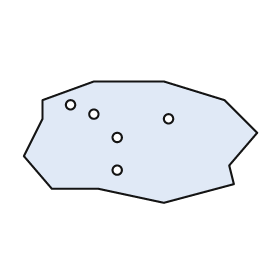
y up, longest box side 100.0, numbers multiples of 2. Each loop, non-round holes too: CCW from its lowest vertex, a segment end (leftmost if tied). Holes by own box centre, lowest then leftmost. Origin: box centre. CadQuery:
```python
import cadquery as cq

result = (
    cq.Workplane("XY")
    .moveTo(10.0, -26.0)
    .lineTo(40.0, -18.0)
    .lineTo(38.0, -10.0)
    .lineTo(50.0, 4.0)
    .lineTo(36.0, 18.0)
    .lineTo(10.0, 26.0)
    .lineTo(-20.0, 26.0)
    .lineTo(-42.0, 18.0)
    .lineTo(-42.0, 10.0)
    .lineTo(-50.0, -6.0)
    .lineTo(-38.0, -20.0)
    .lineTo(-18.0, -20.0)
    .close()
    .moveTo(-10.0, -12.0)
    .circle(2.0)
    .moveTo(-10.0, 2.0)
    .circle(2.0)
    .moveTo(12.0, 10.0)
    .circle(2.0)
    .moveTo(-20.0, 12.0)
    .circle(2.0)
    .moveTo(-30.0, 16.0)
    .circle(2.0)
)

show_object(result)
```